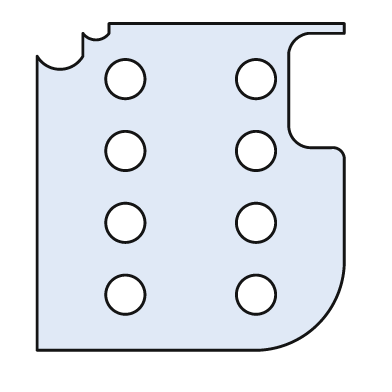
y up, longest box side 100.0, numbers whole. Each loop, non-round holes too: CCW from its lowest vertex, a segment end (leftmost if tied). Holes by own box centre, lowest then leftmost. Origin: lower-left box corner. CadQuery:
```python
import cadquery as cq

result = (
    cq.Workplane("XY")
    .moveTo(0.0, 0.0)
    .lineTo(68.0, 0.0)
    .threePointArc((86.0, 8.0), (94.0, 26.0))
    .lineTo(94.0, 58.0)
    .threePointArc((93.0, 61.0), (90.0, 62.0))
    .lineTo(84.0, 62.0)
    .threePointArc((79.0, 64.0), (77.0, 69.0))
    .lineTo(77.0, 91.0)
    .threePointArc((79.0, 95.0), (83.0, 97.0))
    .lineTo(94.0, 97.0)
    .lineTo(94.0, 100.0)
    .lineTo(22.0, 100.0)
    .lineTo(22.0, 97.0)
    .threePointArc((18.0, 95.0), (14.0, 97.0))
    .lineTo(14.0, 90.0)
    .threePointArc((7.0, 86.0), (0.0, 90.0))
    .close()
    .moveTo(27.0, 17.0)
    .circle(6.0)
    .moveTo(67.0, 17.0)
    .circle(6.0)
    .moveTo(27.0, 39.0)
    .circle(6.0)
    .moveTo(67.0, 39.0)
    .circle(6.0)
    .moveTo(27.0, 61.0)
    .circle(6.0)
    .moveTo(67.0, 61.0)
    .circle(6.0)
    .moveTo(27.0, 83.0)
    .circle(6.0)
    .moveTo(67.0, 83.0)
    .circle(6.0)
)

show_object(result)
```